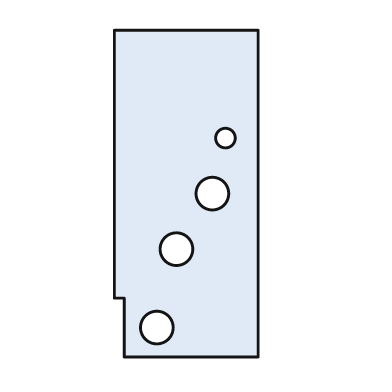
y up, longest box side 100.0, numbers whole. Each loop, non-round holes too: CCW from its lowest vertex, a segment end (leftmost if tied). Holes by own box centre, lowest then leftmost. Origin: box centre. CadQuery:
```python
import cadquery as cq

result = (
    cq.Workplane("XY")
    .moveTo(-19.0, -50.0)
    .lineTo(22.0, -50.0)
    .lineTo(22.0, 50.0)
    .lineTo(-22.0, 50.0)
    .lineTo(-22.0, -32.0)
    .lineTo(-19.0, -32.0)
    .close()
    .moveTo(-9.0, -41.0)
    .circle(5.0)
    .moveTo(-3.0, -17.0)
    .circle(5.0)
    .moveTo(8.0, 0.0)
    .circle(5.0)
    .moveTo(12.0, 17.0)
    .circle(3.0)
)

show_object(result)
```